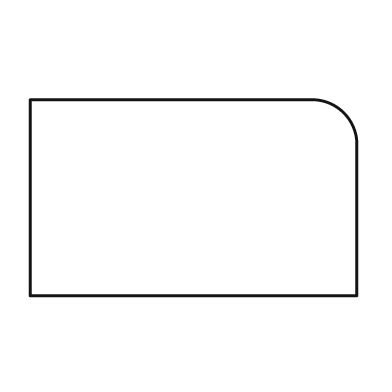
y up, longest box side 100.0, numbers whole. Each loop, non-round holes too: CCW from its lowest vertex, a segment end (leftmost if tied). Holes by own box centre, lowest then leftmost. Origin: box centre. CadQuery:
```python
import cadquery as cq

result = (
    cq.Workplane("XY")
    .moveTo(-50.0, -30.0)
    .lineTo(50.0, -30.0)
    .lineTo(50.0, 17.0)
    .threePointArc((46.0, 26.0), (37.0, 30.0))
    .lineTo(-50.0, 30.0)
    .close()
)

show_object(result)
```